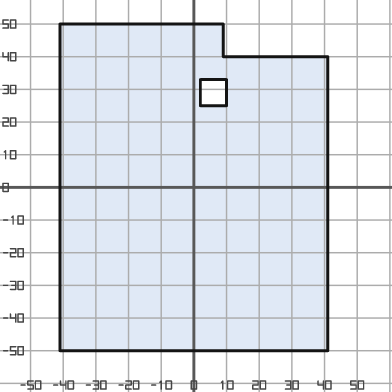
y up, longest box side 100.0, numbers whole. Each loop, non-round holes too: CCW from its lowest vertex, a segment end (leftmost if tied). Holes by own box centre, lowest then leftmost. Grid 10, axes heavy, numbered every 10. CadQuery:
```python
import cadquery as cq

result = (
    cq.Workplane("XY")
    .moveTo(-41.0, -50.0)
    .lineTo(41.0, -50.0)
    .lineTo(41.0, 40.0)
    .lineTo(9.0, 40.0)
    .lineTo(9.0, 50.0)
    .lineTo(-41.0, 50.0)
    .close()
    .moveTo(2.0, 25.0)
    .lineTo(10.0, 25.0)
    .lineTo(10.0, 33.0)
    .lineTo(2.0, 33.0)
    .close()
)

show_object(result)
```